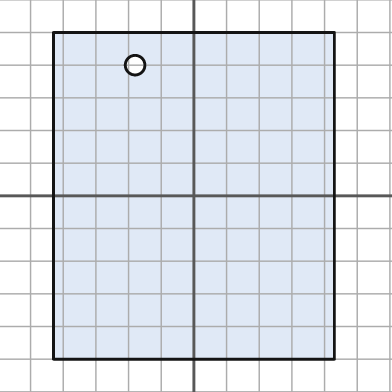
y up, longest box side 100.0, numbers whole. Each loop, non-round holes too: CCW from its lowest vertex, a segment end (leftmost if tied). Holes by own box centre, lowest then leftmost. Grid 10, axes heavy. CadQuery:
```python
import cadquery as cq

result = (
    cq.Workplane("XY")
    .moveTo(-43.0, -50.0)
    .lineTo(43.0, -50.0)
    .lineTo(43.0, 50.0)
    .lineTo(-43.0, 50.0)
    .close()
    .moveTo(-18.0, 40.0)
    .circle(3.0)
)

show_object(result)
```